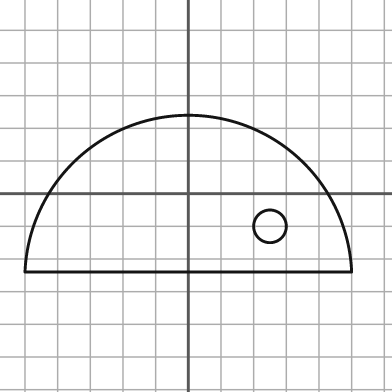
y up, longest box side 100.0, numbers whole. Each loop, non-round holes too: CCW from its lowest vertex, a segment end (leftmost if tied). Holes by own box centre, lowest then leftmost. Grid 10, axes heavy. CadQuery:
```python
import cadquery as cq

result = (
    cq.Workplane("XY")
    .moveTo(-50.0, -24.0)
    .lineTo(50.0, -24.0)
    .threePointArc((0.0, 24.0), (-50.0, -24.0))
    .close()
    .moveTo(25.0, -10.0)
    .circle(5.0)
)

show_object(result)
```